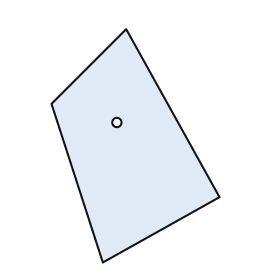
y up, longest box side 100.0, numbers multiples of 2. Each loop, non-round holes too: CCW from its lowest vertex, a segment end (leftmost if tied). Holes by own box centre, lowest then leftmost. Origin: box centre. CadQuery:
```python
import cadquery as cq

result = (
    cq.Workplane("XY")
    .moveTo(-14.0, -50.0)
    .lineTo(36.0, -22.0)
    .lineTo(-4.0, 50.0)
    .lineTo(-36.0, 18.0)
    .close()
    .moveTo(-8.0, 10.0)
    .circle(2.0)
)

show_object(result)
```